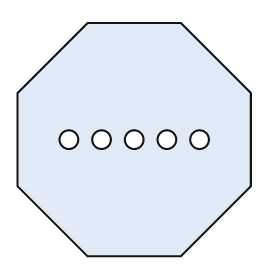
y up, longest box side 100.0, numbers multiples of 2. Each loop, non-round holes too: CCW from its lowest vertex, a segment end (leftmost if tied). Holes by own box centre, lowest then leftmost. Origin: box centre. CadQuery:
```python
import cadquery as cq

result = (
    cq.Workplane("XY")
    .moveTo(-20.0, -50.0)
    .lineTo(20.0, -50.0)
    .lineTo(50.0, -20.0)
    .lineTo(50.0, 20.0)
    .lineTo(20.0, 50.0)
    .lineTo(-20.0, 50.0)
    .lineTo(-50.0, 20.0)
    .lineTo(-50.0, -20.0)
    .close()
    .moveTo(-28.0, 0.0)
    .circle(4.0)
    .moveTo(-14.0, 0.0)
    .circle(4.0)
    .moveTo(0.0, 0.0)
    .circle(4.0)
    .moveTo(14.0, 0.0)
    .circle(4.0)
    .moveTo(28.0, 0.0)
    .circle(4.0)
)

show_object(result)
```